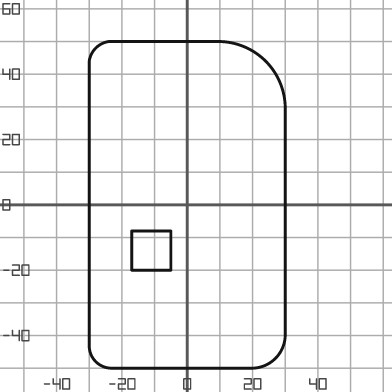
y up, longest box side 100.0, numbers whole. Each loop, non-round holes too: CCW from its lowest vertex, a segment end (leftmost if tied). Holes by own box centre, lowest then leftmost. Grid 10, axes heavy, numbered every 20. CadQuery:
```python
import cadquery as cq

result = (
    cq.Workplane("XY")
    .moveTo(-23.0, -50.0)
    .lineTo(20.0, -50.0)
    .threePointArc((27.0, -47.0), (30.0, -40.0))
    .lineTo(30.0, 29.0)
    .threePointArc((24.0, 44.0), (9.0, 50.0))
    .lineTo(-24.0, 50.0)
    .threePointArc((-28.0, 48.0), (-30.0, 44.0))
    .lineTo(-30.0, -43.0)
    .threePointArc((-28.0, -48.0), (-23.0, -50.0))
    .close()
    .moveTo(-17.0, -20.0)
    .lineTo(-5.0, -20.0)
    .lineTo(-5.0, -8.0)
    .lineTo(-17.0, -8.0)
    .close()
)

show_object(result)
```